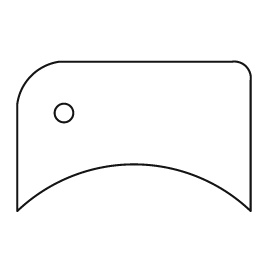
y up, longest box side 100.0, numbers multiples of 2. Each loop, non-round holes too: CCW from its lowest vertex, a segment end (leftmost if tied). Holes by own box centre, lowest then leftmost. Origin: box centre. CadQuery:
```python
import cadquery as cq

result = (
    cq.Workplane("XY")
    .moveTo(-50.0, -32.0)
    .threePointArc((0.0, -12.0), (50.0, -32.0))
    .lineTo(50.0, 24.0)
    .threePointArc((48.0, 30.0), (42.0, 32.0))
    .lineTo(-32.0, 32.0)
    .threePointArc((-44.0, 26.0), (-50.0, 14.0))
    .close()
    .moveTo(-30.0, 10.0)
    .circle(4.0)
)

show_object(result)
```